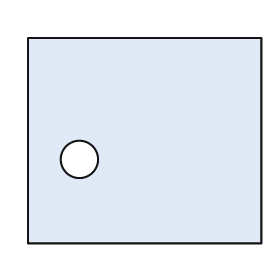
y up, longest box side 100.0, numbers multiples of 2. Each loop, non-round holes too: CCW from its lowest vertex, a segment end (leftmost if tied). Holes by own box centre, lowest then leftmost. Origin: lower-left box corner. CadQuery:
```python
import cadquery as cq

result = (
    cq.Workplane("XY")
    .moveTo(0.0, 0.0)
    .lineTo(100.0, 0.0)
    .lineTo(100.0, 88.0)
    .lineTo(0.0, 88.0)
    .close()
    .moveTo(22.0, 36.0)
    .circle(8.0)
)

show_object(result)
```